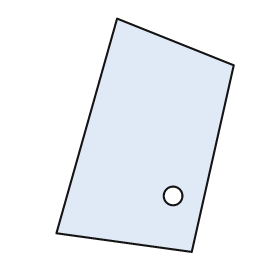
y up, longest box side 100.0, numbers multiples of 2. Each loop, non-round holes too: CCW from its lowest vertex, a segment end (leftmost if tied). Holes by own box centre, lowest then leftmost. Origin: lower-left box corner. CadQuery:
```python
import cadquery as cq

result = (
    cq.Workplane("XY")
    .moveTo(58.0, 0.0)
    .lineTo(76.0, 80.0)
    .lineTo(26.0, 100.0)
    .lineTo(0.0, 8.0)
    .close()
    .moveTo(50.0, 24.0)
    .circle(4.0)
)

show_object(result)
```